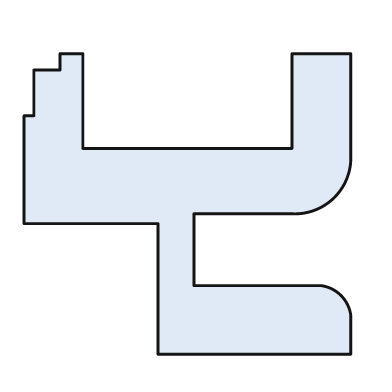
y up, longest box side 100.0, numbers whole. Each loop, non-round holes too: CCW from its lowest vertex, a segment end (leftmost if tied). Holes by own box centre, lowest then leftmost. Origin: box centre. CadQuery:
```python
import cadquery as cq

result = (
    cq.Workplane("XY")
    .moveTo(-9.0, -46.0)
    .lineTo(50.0, -46.0)
    .lineTo(50.0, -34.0)
    .threePointArc((47.0, -28.0), (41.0, -25.0))
    .lineTo(2.0, -25.0)
    .lineTo(2.0, -3.0)
    .lineTo(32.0, -3.0)
    .threePointArc((45.0, 2.0), (50.0, 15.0))
    .lineTo(50.0, 46.0)
    .lineTo(32.0, 46.0)
    .lineTo(32.0, 17.0)
    .lineTo(-32.0, 17.0)
    .lineTo(-32.0, 46.0)
    .lineTo(-39.0, 46.0)
    .lineTo(-39.0, 41.0)
    .lineTo(-47.0, 41.0)
    .lineTo(-47.0, 27.0)
    .lineTo(-50.0, 27.0)
    .lineTo(-50.0, -6.0)
    .lineTo(-9.0, -6.0)
    .close()
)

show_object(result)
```